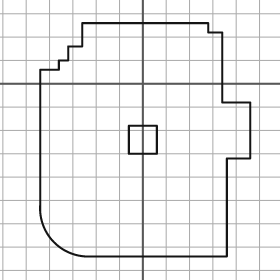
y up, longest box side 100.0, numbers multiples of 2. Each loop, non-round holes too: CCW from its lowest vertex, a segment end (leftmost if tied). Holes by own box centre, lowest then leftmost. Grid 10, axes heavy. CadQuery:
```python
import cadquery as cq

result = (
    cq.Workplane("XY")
    .moveTo(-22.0, -74.0)
    .lineTo(36.0, -74.0)
    .lineTo(36.0, -32.0)
    .lineTo(46.0, -32.0)
    .lineTo(46.0, -8.0)
    .lineTo(34.0, -8.0)
    .lineTo(34.0, 22.0)
    .lineTo(28.0, 22.0)
    .lineTo(28.0, 26.0)
    .lineTo(-26.0, 26.0)
    .lineTo(-26.0, 16.0)
    .lineTo(-32.0, 16.0)
    .lineTo(-32.0, 10.0)
    .lineTo(-36.0, 10.0)
    .lineTo(-36.0, 6.0)
    .lineTo(-44.0, 6.0)
    .lineTo(-44.0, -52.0)
    .threePointArc((-38.0, -68.0), (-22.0, -74.0))
    .close()
    .moveTo(-6.0, -30.0)
    .lineTo(6.0, -30.0)
    .lineTo(6.0, -18.0)
    .lineTo(-6.0, -18.0)
    .close()
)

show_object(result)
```